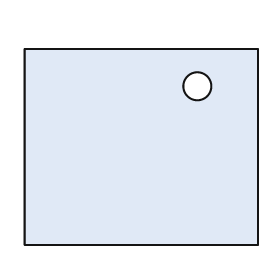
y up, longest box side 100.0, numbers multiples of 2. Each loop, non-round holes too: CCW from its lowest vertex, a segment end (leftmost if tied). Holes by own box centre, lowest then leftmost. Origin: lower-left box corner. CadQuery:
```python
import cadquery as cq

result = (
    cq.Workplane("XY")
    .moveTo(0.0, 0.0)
    .lineTo(100.0, 0.0)
    .lineTo(100.0, 84.0)
    .lineTo(0.0, 84.0)
    .close()
    .moveTo(74.0, 68.0)
    .circle(6.0)
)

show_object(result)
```